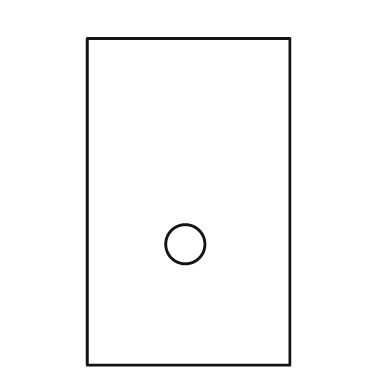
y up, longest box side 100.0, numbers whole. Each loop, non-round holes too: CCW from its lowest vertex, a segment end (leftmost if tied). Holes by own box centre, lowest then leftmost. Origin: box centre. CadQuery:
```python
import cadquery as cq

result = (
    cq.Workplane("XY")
    .moveTo(-31.0, -50.0)
    .lineTo(31.0, -50.0)
    .lineTo(31.0, 50.0)
    .lineTo(-31.0, 50.0)
    .close()
    .moveTo(-1.0, -13.0)
    .circle(6.0)
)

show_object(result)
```